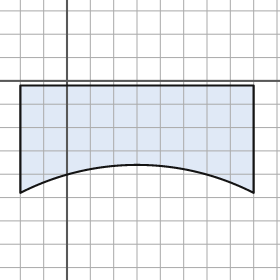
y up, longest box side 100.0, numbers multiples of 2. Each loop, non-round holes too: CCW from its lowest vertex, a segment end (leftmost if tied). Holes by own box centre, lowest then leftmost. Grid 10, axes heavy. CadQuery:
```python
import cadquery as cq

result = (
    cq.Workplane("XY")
    .moveTo(-20.0, -48.0)
    .threePointArc((30.0, -36.0), (80.0, -48.0))
    .lineTo(80.0, -2.0)
    .lineTo(-20.0, -2.0)
    .close()
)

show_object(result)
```